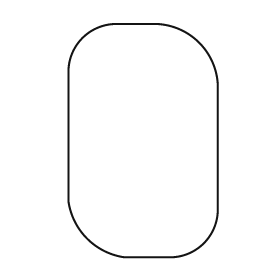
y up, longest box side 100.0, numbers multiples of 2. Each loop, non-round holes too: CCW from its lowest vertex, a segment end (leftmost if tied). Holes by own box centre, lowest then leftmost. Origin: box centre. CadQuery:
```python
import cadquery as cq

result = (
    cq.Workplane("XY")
    .moveTo(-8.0, -50.0)
    .lineTo(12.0, -50.0)
    .threePointArc((26.0, -44.0), (32.0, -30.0))
    .lineTo(32.0, 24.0)
    .threePointArc((24.0, 42.0), (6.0, 50.0))
    .lineTo(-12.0, 50.0)
    .threePointArc((-26.0, 44.0), (-32.0, 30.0))
    .lineTo(-32.0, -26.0)
    .threePointArc((-24.0, -42.0), (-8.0, -50.0))
    .close()
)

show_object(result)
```